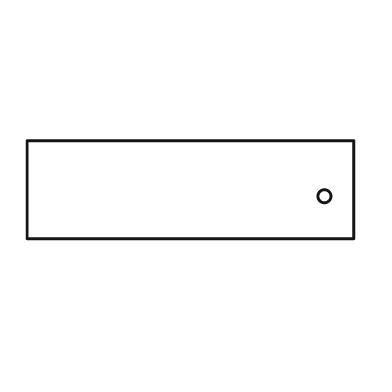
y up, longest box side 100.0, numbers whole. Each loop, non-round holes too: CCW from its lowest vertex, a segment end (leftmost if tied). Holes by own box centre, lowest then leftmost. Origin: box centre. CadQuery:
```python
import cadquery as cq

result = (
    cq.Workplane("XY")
    .moveTo(-50.0, -15.0)
    .lineTo(50.0, -15.0)
    .lineTo(50.0, 15.0)
    .lineTo(-50.0, 15.0)
    .close()
    .moveTo(41.0, -2.0)
    .circle(2.0)
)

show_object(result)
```